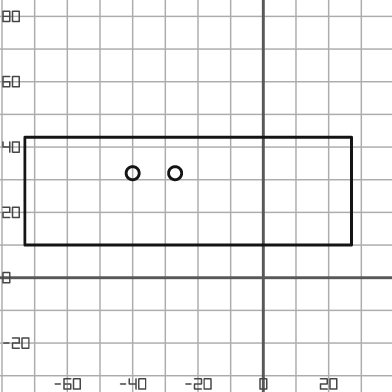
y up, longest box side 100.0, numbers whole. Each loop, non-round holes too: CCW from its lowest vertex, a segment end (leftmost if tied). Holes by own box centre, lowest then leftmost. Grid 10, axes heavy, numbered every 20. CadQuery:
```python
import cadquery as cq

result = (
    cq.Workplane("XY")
    .moveTo(-73.0, 10.0)
    .lineTo(27.0, 10.0)
    .lineTo(27.0, 43.0)
    .lineTo(-73.0, 43.0)
    .close()
    .moveTo(-40.0, 32.0)
    .circle(2.0)
    .moveTo(-27.0, 32.0)
    .circle(2.0)
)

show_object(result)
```